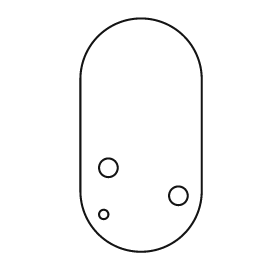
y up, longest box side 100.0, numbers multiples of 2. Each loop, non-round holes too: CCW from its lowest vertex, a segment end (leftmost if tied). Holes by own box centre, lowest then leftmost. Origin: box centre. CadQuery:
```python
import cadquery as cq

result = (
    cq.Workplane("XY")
    .moveTo(-26.0, -24.0)
    .threePointArc((0.0, -50.0), (26.0, -24.0))
    .lineTo(26.0, 24.0)
    .threePointArc((0.0, 50.0), (-26.0, 24.0))
    .close()
    .moveTo(-16.0, -34.0)
    .circle(2.0)
    .moveTo(16.0, -26.0)
    .circle(4.0)
    .moveTo(-14.0, -14.0)
    .circle(4.0)
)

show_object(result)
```